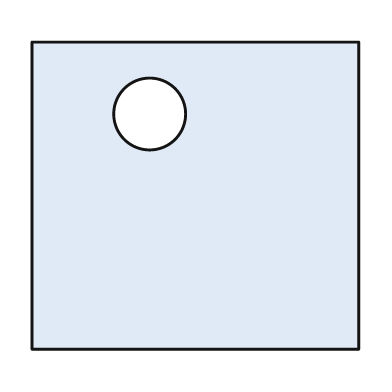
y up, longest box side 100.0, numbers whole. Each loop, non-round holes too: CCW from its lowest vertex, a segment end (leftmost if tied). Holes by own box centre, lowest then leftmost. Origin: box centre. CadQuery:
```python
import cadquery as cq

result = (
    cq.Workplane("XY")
    .moveTo(-50.0, -47.0)
    .lineTo(50.0, -47.0)
    .lineTo(50.0, 47.0)
    .lineTo(-50.0, 47.0)
    .close()
    .moveTo(-14.0, 25.0)
    .circle(11.0)
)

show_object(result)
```